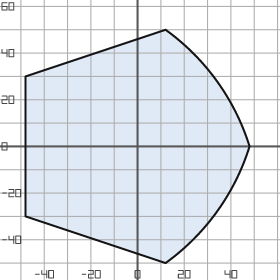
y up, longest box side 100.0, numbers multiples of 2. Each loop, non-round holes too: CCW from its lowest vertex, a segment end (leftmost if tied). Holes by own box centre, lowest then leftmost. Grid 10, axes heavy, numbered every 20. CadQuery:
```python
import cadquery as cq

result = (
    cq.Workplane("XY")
    .moveTo(12.0, -50.0)
    .threePointArc((34.0, -28.0), (48.0, 0.0))
    .threePointArc((34.0, 28.0), (12.0, 50.0))
    .lineTo(-48.0, 30.0)
    .lineTo(-48.0, -30.0)
    .close()
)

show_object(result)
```